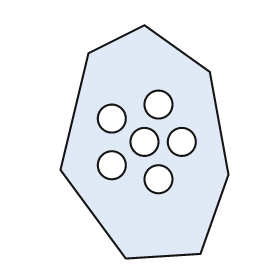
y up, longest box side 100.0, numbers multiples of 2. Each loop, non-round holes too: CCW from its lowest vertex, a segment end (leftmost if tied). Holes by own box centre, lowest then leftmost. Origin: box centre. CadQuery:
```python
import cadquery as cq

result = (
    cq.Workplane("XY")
    .moveTo(-8.0, -50.0)
    .lineTo(24.0, -48.0)
    .lineTo(36.0, -14.0)
    .lineTo(28.0, 30.0)
    .lineTo(0.0, 50.0)
    .lineTo(-24.0, 38.0)
    .lineTo(-36.0, -12.0)
    .close()
    .moveTo(6.0, -16.0)
    .circle(6.0)
    .moveTo(-14.0, -10.0)
    .circle(6.0)
    .moveTo(0.0, 0.0)
    .circle(6.0)
    .moveTo(16.0, 0.0)
    .circle(6.0)
    .moveTo(-14.0, 10.0)
    .circle(6.0)
    .moveTo(6.0, 16.0)
    .circle(6.0)
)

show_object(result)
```